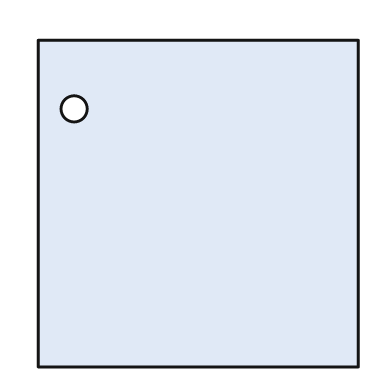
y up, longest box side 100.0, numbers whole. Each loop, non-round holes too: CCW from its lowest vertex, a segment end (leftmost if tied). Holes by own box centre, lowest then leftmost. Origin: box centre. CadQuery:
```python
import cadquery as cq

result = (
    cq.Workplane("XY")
    .moveTo(-49.0, -50.0)
    .lineTo(49.0, -50.0)
    .lineTo(49.0, 50.0)
    .lineTo(-49.0, 50.0)
    .close()
    .moveTo(-38.0, 29.0)
    .circle(4.0)
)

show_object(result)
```